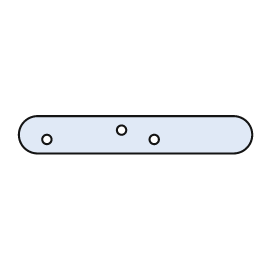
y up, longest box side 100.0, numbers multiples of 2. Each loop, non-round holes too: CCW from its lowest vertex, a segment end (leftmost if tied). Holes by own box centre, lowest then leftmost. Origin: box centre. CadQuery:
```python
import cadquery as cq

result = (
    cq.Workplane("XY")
    .moveTo(-42.0, -8.0)
    .lineTo(42.0, -8.0)
    .threePointArc((50.0, 0.0), (42.0, 8.0))
    .lineTo(-42.0, 8.0)
    .threePointArc((-50.0, 0.0), (-42.0, -8.0))
    .close()
    .moveTo(-38.0, -2.0)
    .circle(2.0)
    .moveTo(8.0, -2.0)
    .circle(2.0)
    .moveTo(-6.0, 2.0)
    .circle(2.0)
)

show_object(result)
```